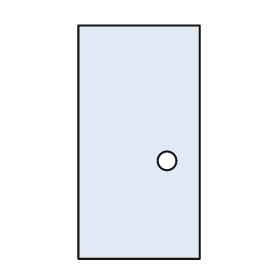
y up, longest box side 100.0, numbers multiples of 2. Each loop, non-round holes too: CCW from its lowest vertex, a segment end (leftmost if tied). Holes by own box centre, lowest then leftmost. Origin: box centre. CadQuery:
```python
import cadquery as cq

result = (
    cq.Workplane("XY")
    .moveTo(-26.0, -50.0)
    .lineTo(26.0, -50.0)
    .lineTo(26.0, 50.0)
    .lineTo(-26.0, 50.0)
    .close()
    .moveTo(12.0, -8.0)
    .circle(4.0)
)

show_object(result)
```